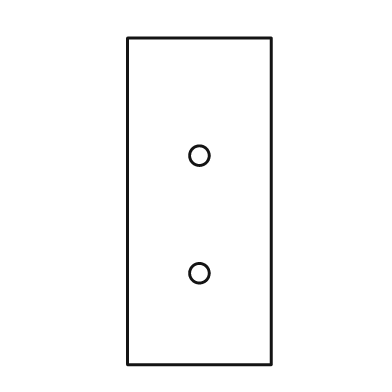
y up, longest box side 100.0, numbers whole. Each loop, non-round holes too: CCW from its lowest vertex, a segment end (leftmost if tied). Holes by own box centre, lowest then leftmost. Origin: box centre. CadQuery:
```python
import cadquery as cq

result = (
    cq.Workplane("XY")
    .moveTo(-22.0, -50.0)
    .lineTo(22.0, -50.0)
    .lineTo(22.0, 50.0)
    .lineTo(-22.0, 50.0)
    .close()
    .moveTo(0.0, -22.0)
    .circle(3.0)
    .moveTo(0.0, 14.0)
    .circle(3.0)
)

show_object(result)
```